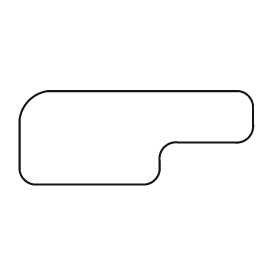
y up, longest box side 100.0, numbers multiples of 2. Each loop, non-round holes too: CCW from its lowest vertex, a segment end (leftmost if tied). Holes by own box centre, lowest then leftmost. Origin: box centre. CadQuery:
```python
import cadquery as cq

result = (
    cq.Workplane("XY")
    .moveTo(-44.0, -20.0)
    .lineTo(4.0, -20.0)
    .threePointArc((8.0, -18.0), (10.0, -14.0))
    .lineTo(10.0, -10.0)
    .threePointArc((12.0, -4.0), (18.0, -2.0))
    .lineTo(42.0, -2.0)
    .threePointArc((48.0, 0.0), (50.0, 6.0))
    .lineTo(50.0, 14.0)
    .threePointArc((48.0, 18.0), (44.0, 20.0))
    .lineTo(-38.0, 20.0)
    .threePointArc((-46.0, 16.0), (-50.0, 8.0))
    .lineTo(-50.0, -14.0)
    .threePointArc((-48.0, -18.0), (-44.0, -20.0))
    .close()
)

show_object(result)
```